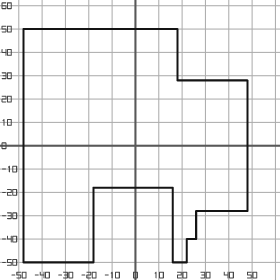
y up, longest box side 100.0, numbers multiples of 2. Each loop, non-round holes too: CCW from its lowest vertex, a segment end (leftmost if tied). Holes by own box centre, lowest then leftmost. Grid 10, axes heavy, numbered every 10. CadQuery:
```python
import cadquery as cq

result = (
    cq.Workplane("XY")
    .moveTo(-48.0, -50.0)
    .lineTo(-18.0, -50.0)
    .lineTo(-18.0, -18.0)
    .lineTo(16.0, -18.0)
    .lineTo(16.0, -50.0)
    .lineTo(22.0, -50.0)
    .lineTo(22.0, -40.0)
    .lineTo(26.0, -40.0)
    .lineTo(26.0, -28.0)
    .lineTo(48.0, -28.0)
    .lineTo(48.0, 28.0)
    .lineTo(18.0, 28.0)
    .lineTo(18.0, 50.0)
    .lineTo(-48.0, 50.0)
    .close()
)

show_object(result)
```